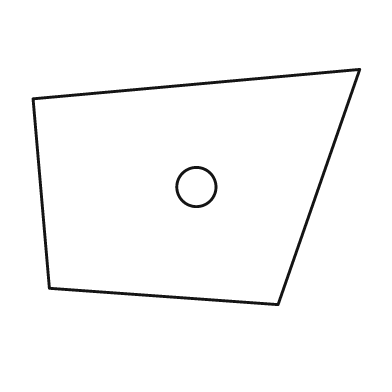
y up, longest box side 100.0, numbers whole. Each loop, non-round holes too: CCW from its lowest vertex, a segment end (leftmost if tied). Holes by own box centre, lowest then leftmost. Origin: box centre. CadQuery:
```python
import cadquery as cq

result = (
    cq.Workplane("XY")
    .moveTo(25.0, -36.0)
    .lineTo(50.0, 36.0)
    .lineTo(-50.0, 27.0)
    .lineTo(-45.0, -31.0)
    .close()
    .moveTo(0.0, 0.0)
    .circle(6.0)
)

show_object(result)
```